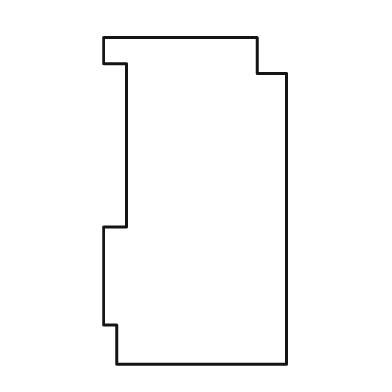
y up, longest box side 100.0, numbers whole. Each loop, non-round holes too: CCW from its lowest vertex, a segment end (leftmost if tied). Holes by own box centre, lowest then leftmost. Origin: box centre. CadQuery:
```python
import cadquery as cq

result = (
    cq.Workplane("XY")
    .moveTo(-24.0, -50.0)
    .lineTo(28.0, -50.0)
    .lineTo(28.0, 39.0)
    .lineTo(19.0, 39.0)
    .lineTo(19.0, 50.0)
    .lineTo(-28.0, 50.0)
    .lineTo(-28.0, 42.0)
    .lineTo(-21.0, 42.0)
    .lineTo(-21.0, -8.0)
    .lineTo(-28.0, -8.0)
    .lineTo(-28.0, -38.0)
    .lineTo(-24.0, -38.0)
    .close()
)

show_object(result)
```